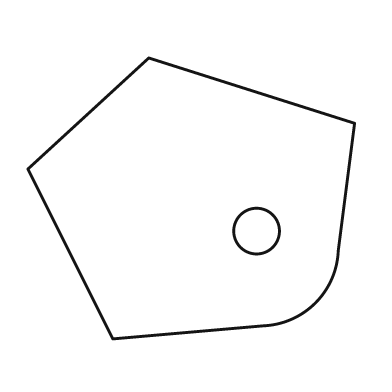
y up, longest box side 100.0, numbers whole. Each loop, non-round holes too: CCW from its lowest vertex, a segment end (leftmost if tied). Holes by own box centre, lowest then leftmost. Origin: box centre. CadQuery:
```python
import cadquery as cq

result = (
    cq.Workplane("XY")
    .moveTo(-24.0, -43.0)
    .lineTo(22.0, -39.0)
    .threePointArc((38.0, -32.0), (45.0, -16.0))
    .lineTo(50.0, 23.0)
    .lineTo(-13.0, 43.0)
    .lineTo(-50.0, 9.0)
    .close()
    .moveTo(20.0, -10.0)
    .circle(7.0)
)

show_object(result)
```